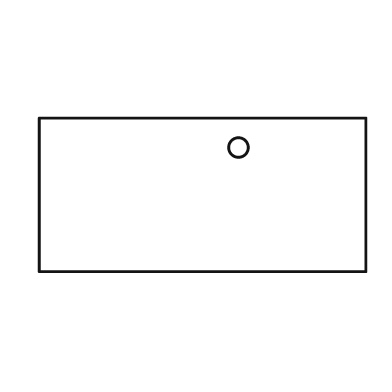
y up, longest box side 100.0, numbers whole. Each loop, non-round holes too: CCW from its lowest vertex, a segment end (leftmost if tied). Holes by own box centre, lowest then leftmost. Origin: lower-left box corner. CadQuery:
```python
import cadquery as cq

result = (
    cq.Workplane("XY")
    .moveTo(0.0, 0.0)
    .lineTo(100.0, 0.0)
    .lineTo(100.0, 47.0)
    .lineTo(0.0, 47.0)
    .close()
    .moveTo(61.0, 38.0)
    .circle(3.0)
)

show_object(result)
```